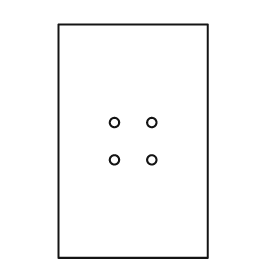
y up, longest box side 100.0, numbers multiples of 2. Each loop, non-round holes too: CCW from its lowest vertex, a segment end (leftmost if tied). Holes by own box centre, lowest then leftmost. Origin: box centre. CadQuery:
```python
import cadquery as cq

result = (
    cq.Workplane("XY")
    .moveTo(-32.0, -50.0)
    .lineTo(32.0, -50.0)
    .lineTo(32.0, 50.0)
    .lineTo(-32.0, 50.0)
    .close()
    .moveTo(-8.0, -8.0)
    .circle(2.0)
    .moveTo(8.0, -8.0)
    .circle(2.0)
    .moveTo(-8.0, 8.0)
    .circle(2.0)
    .moveTo(8.0, 8.0)
    .circle(2.0)
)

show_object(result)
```